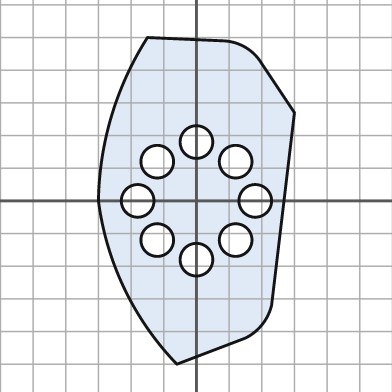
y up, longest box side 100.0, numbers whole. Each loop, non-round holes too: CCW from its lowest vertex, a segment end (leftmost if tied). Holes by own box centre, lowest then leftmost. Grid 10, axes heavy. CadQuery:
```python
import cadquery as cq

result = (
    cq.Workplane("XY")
    .moveTo(-6.0, -50.0)
    .lineTo(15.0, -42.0)
    .threePointArc((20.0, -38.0), (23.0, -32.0))
    .lineTo(30.0, 27.0)
    .lineTo(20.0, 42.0)
    .threePointArc((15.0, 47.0), (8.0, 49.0))
    .lineTo(-15.0, 50.0)
    .threePointArc((-26.0, 26.0), (-30.0, 0.0))
    .threePointArc((-22.0, -27.0), (-6.0, -50.0))
    .close()
    .moveTo(0.0, -18.0)
    .circle(5.0)
    .moveTo(-12.0, -12.0)
    .circle(5.0)
    .moveTo(12.0, -12.0)
    .circle(5.0)
    .moveTo(-18.0, 0.0)
    .circle(5.0)
    .moveTo(18.0, 0.0)
    .circle(5.0)
    .moveTo(-12.0, 12.0)
    .circle(5.0)
    .moveTo(12.0, 12.0)
    .circle(5.0)
    .moveTo(0.0, 18.0)
    .circle(5.0)
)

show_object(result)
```